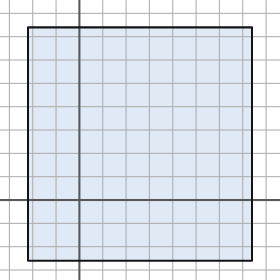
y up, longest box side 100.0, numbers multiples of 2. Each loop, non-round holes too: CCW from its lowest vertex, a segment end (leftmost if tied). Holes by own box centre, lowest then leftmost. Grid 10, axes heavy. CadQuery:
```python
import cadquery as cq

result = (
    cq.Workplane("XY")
    .moveTo(-22.0, -26.0)
    .lineTo(74.0, -26.0)
    .lineTo(74.0, 74.0)
    .lineTo(-22.0, 74.0)
    .close()
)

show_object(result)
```